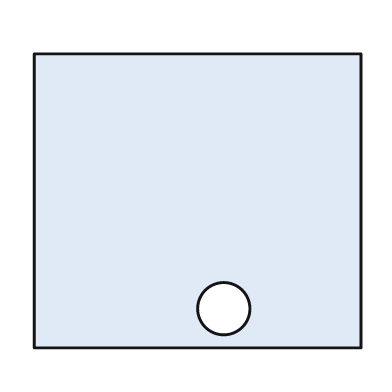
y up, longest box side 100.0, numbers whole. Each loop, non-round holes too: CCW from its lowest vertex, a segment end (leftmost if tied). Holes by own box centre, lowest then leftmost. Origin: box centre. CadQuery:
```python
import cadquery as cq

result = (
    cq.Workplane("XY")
    .moveTo(-50.0, -45.0)
    .lineTo(50.0, -45.0)
    .lineTo(50.0, 45.0)
    .lineTo(-50.0, 45.0)
    .close()
    .moveTo(8.0, -33.0)
    .circle(8.0)
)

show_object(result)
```